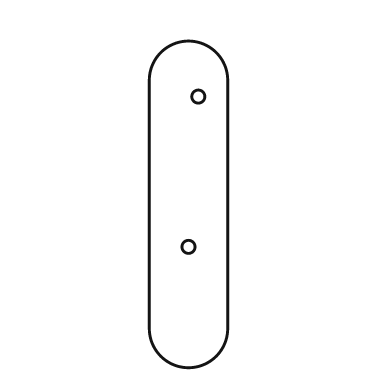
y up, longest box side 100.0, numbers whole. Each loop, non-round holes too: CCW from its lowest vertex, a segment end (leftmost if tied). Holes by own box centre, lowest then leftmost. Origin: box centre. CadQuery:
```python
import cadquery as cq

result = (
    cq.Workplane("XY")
    .moveTo(-12.0, -38.0)
    .threePointArc((0.0, -50.0), (12.0, -38.0))
    .lineTo(12.0, 38.0)
    .threePointArc((0.0, 50.0), (-12.0, 38.0))
    .close()
    .moveTo(0.0, -13.0)
    .circle(2.0)
    .moveTo(3.0, 33.0)
    .circle(2.0)
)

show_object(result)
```